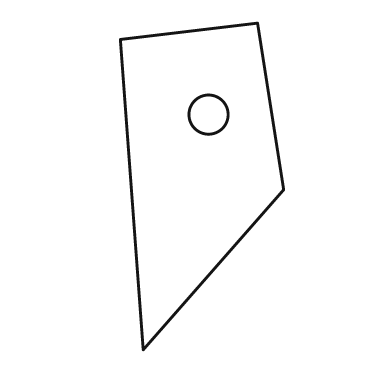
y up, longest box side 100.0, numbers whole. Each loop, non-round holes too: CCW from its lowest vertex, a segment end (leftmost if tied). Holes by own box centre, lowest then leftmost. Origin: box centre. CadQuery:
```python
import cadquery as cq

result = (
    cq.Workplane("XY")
    .moveTo(-18.0, -50.0)
    .lineTo(25.0, -1.0)
    .lineTo(17.0, 50.0)
    .lineTo(-25.0, 45.0)
    .close()
    .moveTo(2.0, 22.0)
    .circle(6.0)
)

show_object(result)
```